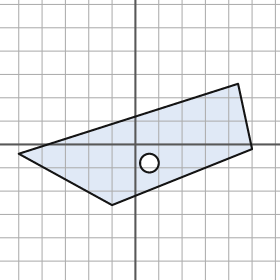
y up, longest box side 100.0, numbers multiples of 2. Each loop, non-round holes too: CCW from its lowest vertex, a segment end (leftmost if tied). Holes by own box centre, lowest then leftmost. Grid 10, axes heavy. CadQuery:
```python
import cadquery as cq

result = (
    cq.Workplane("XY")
    .moveTo(-10.0, -26.0)
    .lineTo(50.0, -2.0)
    .lineTo(44.0, 26.0)
    .lineTo(-50.0, -4.0)
    .close()
    .moveTo(6.0, -8.0)
    .circle(4.0)
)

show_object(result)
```